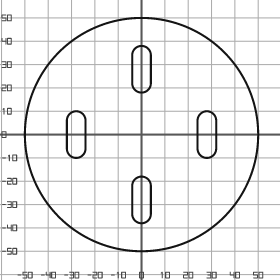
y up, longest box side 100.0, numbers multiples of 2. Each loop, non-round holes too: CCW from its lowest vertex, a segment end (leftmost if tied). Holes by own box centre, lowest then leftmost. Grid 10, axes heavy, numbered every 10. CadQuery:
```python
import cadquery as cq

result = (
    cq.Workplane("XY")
    .moveTo(0.0, 0.0)
    .circle(50.0)
    .moveTo(-4.0, -34.0)
    .threePointArc((0.0, -38.0), (4.0, -34.0))
    .lineTo(4.0, -22.0)
    .threePointArc((0.0, -18.0), (-4.0, -22.0))
    .close()
    .moveTo(-32.0, -6.0)
    .threePointArc((-28.0, -10.0), (-24.0, -6.0))
    .lineTo(-24.0, 6.0)
    .threePointArc((-28.0, 10.0), (-32.0, 6.0))
    .close()
    .moveTo(24.0, -6.0)
    .threePointArc((28.0, -10.0), (32.0, -6.0))
    .lineTo(32.0, 6.0)
    .threePointArc((28.0, 10.0), (24.0, 6.0))
    .close()
    .moveTo(-4.0, 22.0)
    .threePointArc((0.0, 18.0), (4.0, 22.0))
    .lineTo(4.0, 34.0)
    .threePointArc((0.0, 38.0), (-4.0, 34.0))
    .close()
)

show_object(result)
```